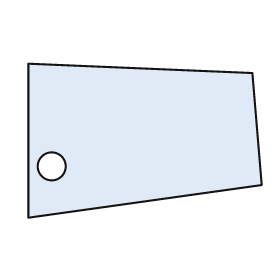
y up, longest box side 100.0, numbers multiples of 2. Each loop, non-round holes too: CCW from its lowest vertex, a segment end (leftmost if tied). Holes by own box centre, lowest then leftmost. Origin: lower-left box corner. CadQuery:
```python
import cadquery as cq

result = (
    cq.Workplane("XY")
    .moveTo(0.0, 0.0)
    .lineTo(100.0, 14.0)
    .lineTo(96.0, 62.0)
    .lineTo(0.0, 66.0)
    .close()
    .moveTo(10.0, 22.0)
    .circle(6.0)
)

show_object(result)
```